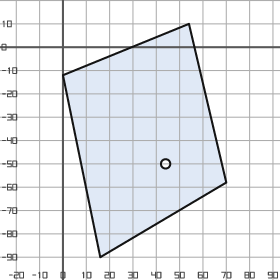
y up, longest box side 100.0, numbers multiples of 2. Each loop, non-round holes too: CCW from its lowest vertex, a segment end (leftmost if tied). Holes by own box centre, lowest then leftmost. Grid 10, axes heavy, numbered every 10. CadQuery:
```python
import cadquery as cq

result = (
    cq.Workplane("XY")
    .moveTo(16.0, -90.0)
    .lineTo(70.0, -58.0)
    .lineTo(54.0, 10.0)
    .lineTo(0.0, -12.0)
    .close()
    .moveTo(44.0, -50.0)
    .circle(2.0)
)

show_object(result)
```